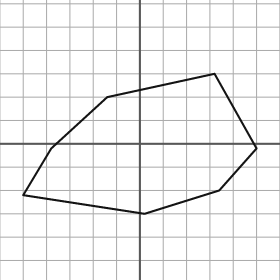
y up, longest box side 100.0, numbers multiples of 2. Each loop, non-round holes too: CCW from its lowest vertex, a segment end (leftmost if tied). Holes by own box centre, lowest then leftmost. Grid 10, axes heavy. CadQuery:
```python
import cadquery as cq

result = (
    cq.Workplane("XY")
    .moveTo(2.0, -30.0)
    .lineTo(34.0, -20.0)
    .lineTo(50.0, -2.0)
    .lineTo(32.0, 30.0)
    .lineTo(-14.0, 20.0)
    .lineTo(-38.0, -2.0)
    .lineTo(-50.0, -22.0)
    .close()
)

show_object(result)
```